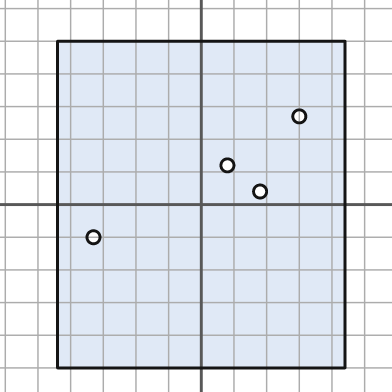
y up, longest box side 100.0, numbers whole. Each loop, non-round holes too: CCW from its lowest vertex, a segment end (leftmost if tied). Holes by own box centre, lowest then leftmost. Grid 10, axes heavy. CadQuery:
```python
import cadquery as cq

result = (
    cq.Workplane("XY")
    .moveTo(-44.0, -50.0)
    .lineTo(44.0, -50.0)
    .lineTo(44.0, 50.0)
    .lineTo(-44.0, 50.0)
    .close()
    .moveTo(-33.0, -10.0)
    .circle(2.0)
    .moveTo(18.0, 4.0)
    .circle(2.0)
    .moveTo(8.0, 12.0)
    .circle(2.0)
    .moveTo(30.0, 27.0)
    .circle(2.0)
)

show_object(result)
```